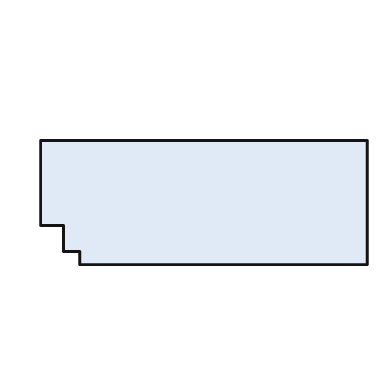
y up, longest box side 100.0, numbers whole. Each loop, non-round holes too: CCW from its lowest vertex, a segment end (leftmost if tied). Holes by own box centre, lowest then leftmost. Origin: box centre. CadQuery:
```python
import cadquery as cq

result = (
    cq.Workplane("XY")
    .moveTo(-38.0, -19.0)
    .lineTo(50.0, -19.0)
    .lineTo(50.0, 19.0)
    .lineTo(-50.0, 19.0)
    .lineTo(-50.0, -7.0)
    .lineTo(-43.0, -7.0)
    .lineTo(-43.0, -15.0)
    .lineTo(-38.0, -15.0)
    .close()
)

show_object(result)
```